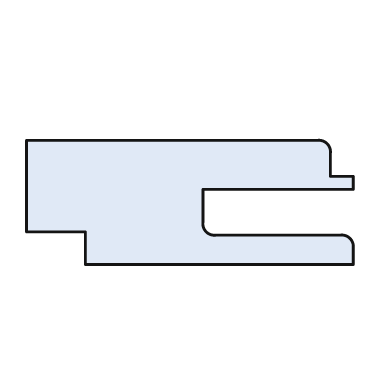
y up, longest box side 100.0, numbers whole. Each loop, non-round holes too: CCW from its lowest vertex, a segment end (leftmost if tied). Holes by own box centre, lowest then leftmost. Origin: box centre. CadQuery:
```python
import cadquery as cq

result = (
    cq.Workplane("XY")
    .moveTo(-32.0, -19.0)
    .lineTo(50.0, -19.0)
    .lineTo(50.0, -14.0)
    .threePointArc((49.0, -11.0), (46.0, -10.0))
    .lineTo(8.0, -10.0)
    .threePointArc((5.0, -9.0), (4.0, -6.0))
    .lineTo(4.0, 4.0)
    .lineTo(50.0, 4.0)
    .lineTo(50.0, 8.0)
    .lineTo(43.0, 8.0)
    .lineTo(43.0, 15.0)
    .threePointArc((42.0, 18.0), (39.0, 19.0))
    .lineTo(-50.0, 19.0)
    .lineTo(-50.0, -9.0)
    .lineTo(-32.0, -9.0)
    .close()
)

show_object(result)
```